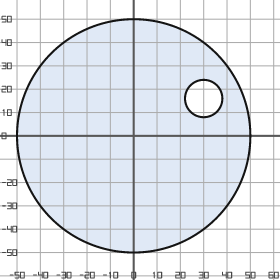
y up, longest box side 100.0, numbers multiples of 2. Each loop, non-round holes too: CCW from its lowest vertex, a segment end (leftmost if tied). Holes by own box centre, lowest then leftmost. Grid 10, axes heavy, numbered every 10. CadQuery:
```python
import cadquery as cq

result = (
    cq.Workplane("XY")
    .moveTo(0.0, 0.0)
    .circle(50.0)
    .moveTo(30.0, 16.0)
    .circle(8.0)
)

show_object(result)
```